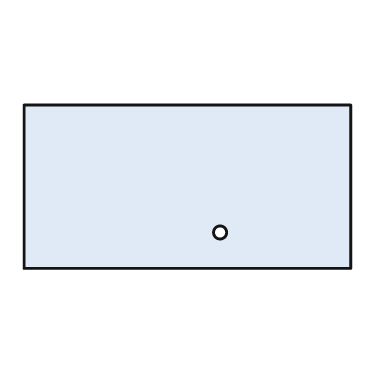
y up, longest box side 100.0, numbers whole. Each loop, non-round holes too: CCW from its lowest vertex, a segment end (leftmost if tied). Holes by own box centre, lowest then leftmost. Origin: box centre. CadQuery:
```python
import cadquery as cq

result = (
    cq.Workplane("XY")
    .moveTo(-50.0, -25.0)
    .lineTo(50.0, -25.0)
    .lineTo(50.0, 25.0)
    .lineTo(-50.0, 25.0)
    .close()
    .moveTo(10.0, -14.0)
    .circle(2.0)
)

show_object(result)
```